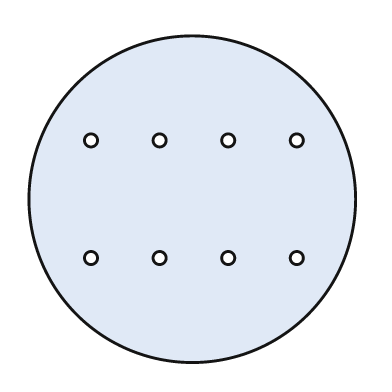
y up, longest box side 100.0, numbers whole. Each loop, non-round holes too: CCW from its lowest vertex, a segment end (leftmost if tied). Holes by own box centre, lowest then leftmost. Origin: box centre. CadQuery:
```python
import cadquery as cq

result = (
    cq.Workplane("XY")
    .moveTo(0.0, 0.0)
    .circle(50.0)
    .moveTo(-31.0, -18.0)
    .circle(2.0)
    .moveTo(-10.0, -18.0)
    .circle(2.0)
    .moveTo(11.0, -18.0)
    .circle(2.0)
    .moveTo(32.0, -18.0)
    .circle(2.0)
    .moveTo(-31.0, 18.0)
    .circle(2.0)
    .moveTo(-10.0, 18.0)
    .circle(2.0)
    .moveTo(11.0, 18.0)
    .circle(2.0)
    .moveTo(32.0, 18.0)
    .circle(2.0)
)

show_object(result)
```